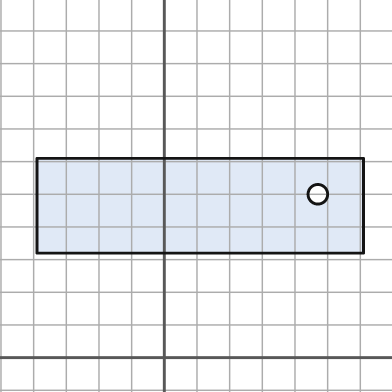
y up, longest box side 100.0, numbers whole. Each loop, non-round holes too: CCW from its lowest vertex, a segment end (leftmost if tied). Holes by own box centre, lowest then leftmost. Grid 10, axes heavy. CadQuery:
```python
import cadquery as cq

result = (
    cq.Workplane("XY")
    .moveTo(-39.0, 32.0)
    .lineTo(61.0, 32.0)
    .lineTo(61.0, 61.0)
    .lineTo(-39.0, 61.0)
    .close()
    .moveTo(47.0, 50.0)
    .circle(3.0)
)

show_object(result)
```